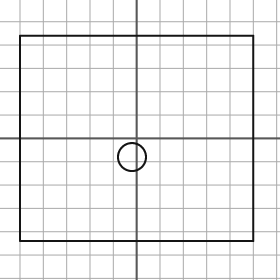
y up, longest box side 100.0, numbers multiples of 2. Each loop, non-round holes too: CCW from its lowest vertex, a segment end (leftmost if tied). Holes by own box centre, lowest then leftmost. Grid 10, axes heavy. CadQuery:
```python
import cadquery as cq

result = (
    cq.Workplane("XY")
    .moveTo(-50.0, -44.0)
    .lineTo(50.0, -44.0)
    .lineTo(50.0, 44.0)
    .lineTo(-50.0, 44.0)
    .close()
    .moveTo(-2.0, -8.0)
    .circle(6.0)
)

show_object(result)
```